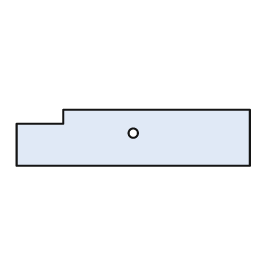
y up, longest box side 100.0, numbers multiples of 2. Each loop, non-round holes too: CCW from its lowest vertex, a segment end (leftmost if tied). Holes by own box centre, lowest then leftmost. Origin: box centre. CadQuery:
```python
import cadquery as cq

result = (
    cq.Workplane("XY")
    .moveTo(-50.0, -12.0)
    .lineTo(50.0, -12.0)
    .lineTo(50.0, 12.0)
    .lineTo(-30.0, 12.0)
    .lineTo(-30.0, 6.0)
    .lineTo(-50.0, 6.0)
    .close()
    .moveTo(0.0, 2.0)
    .circle(2.0)
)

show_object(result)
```